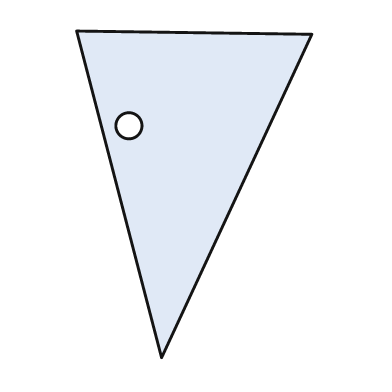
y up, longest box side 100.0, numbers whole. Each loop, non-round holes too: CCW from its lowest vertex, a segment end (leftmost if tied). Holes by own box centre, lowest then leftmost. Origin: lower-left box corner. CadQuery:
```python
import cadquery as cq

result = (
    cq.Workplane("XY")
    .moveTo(26.0, 0.0)
    .lineTo(72.0, 99.0)
    .lineTo(0.0, 100.0)
    .close()
    .moveTo(16.0, 71.0)
    .circle(4.0)
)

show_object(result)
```